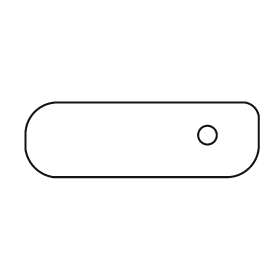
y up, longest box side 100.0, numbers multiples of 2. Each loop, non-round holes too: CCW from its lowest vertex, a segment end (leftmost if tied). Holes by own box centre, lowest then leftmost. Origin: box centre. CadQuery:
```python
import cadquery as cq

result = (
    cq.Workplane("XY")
    .moveTo(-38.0, -16.0)
    .lineTo(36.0, -16.0)
    .threePointArc((46.0, -12.0), (50.0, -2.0))
    .lineTo(50.0, 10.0)
    .threePointArc((48.0, 14.0), (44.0, 16.0))
    .lineTo(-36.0, 16.0)
    .threePointArc((-46.0, 12.0), (-50.0, 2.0))
    .lineTo(-50.0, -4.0)
    .threePointArc((-46.0, -12.0), (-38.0, -16.0))
    .close()
    .moveTo(28.0, 2.0)
    .circle(4.0)
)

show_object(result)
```